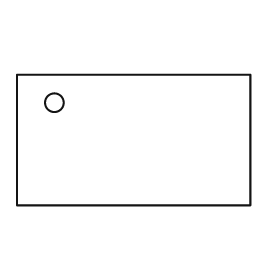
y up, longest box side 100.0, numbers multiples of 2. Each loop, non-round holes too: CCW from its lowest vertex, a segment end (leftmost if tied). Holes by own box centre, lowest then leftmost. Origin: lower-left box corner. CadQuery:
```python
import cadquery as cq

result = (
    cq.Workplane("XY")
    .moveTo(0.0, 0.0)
    .lineTo(100.0, 0.0)
    .lineTo(100.0, 56.0)
    .lineTo(0.0, 56.0)
    .close()
    .moveTo(16.0, 44.0)
    .circle(4.0)
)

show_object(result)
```